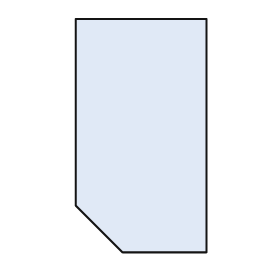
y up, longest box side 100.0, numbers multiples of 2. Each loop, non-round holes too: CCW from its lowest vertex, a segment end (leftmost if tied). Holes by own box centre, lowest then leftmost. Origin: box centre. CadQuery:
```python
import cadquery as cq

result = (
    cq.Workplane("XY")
    .moveTo(-8.0, -50.0)
    .lineTo(28.0, -50.0)
    .lineTo(28.0, 50.0)
    .lineTo(-28.0, 50.0)
    .lineTo(-28.0, -30.0)
    .close()
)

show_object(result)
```